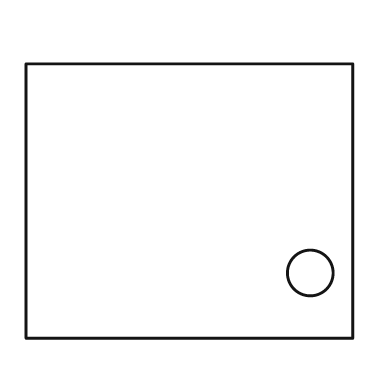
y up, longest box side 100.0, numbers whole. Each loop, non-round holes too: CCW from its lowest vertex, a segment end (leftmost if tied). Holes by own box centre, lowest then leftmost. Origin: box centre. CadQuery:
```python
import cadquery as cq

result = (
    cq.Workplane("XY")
    .moveTo(-50.0, -42.0)
    .lineTo(50.0, -42.0)
    .lineTo(50.0, 42.0)
    .lineTo(-50.0, 42.0)
    .close()
    .moveTo(37.0, -22.0)
    .circle(7.0)
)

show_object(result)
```